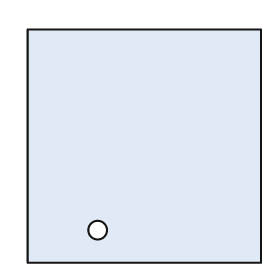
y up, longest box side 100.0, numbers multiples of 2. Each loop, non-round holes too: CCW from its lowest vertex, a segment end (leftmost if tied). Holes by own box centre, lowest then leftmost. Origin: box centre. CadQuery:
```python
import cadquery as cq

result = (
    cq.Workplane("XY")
    .moveTo(-50.0, -50.0)
    .lineTo(50.0, -50.0)
    .lineTo(50.0, 50.0)
    .lineTo(-50.0, 50.0)
    .close()
    .moveTo(-20.0, -36.0)
    .circle(4.0)
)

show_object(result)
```